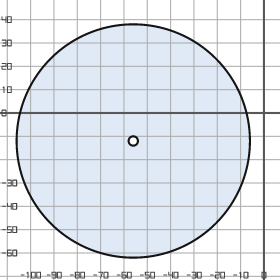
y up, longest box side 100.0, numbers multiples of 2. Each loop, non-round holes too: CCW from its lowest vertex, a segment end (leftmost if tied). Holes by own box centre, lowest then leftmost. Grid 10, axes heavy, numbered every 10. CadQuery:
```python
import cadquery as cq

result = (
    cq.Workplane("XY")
    .moveTo(-56.0, -12.0)
    .circle(50.0)
    .moveTo(-56.0, -12.0)
    .circle(2.0)
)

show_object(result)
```